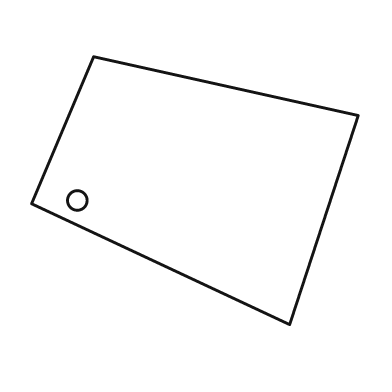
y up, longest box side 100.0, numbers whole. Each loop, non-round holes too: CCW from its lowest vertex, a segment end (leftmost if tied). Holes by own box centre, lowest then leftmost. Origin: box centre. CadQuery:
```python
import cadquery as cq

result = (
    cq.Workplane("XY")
    .moveTo(29.0, -41.0)
    .lineTo(50.0, 23.0)
    .lineTo(-31.0, 41.0)
    .lineTo(-50.0, -4.0)
    .close()
    .moveTo(-36.0, -3.0)
    .circle(3.0)
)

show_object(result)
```